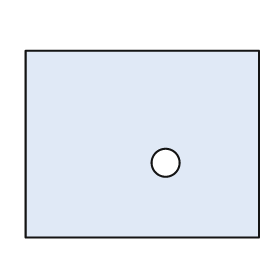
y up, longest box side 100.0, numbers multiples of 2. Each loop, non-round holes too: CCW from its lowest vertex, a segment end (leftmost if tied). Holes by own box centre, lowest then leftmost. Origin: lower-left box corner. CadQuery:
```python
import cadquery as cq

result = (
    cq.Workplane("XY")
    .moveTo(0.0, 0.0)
    .lineTo(100.0, 0.0)
    .lineTo(100.0, 80.0)
    .lineTo(0.0, 80.0)
    .close()
    .moveTo(60.0, 32.0)
    .circle(6.0)
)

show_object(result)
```